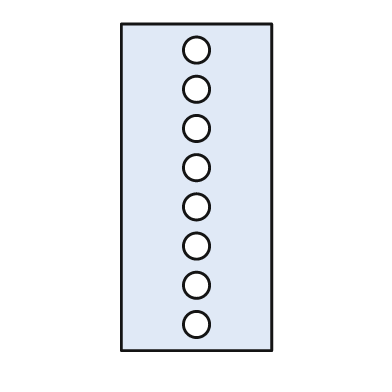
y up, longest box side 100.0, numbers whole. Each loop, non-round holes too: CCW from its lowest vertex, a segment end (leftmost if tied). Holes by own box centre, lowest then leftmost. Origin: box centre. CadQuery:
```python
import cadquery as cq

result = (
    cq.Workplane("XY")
    .moveTo(-23.0, -50.0)
    .lineTo(23.0, -50.0)
    .lineTo(23.0, 50.0)
    .lineTo(-23.0, 50.0)
    .close()
    .moveTo(0.0, -42.0)
    .circle(4.0)
    .moveTo(0.0, -30.0)
    .circle(4.0)
    .moveTo(0.0, -18.0)
    .circle(4.0)
    .moveTo(0.0, -6.0)
    .circle(4.0)
    .moveTo(0.0, 6.0)
    .circle(4.0)
    .moveTo(0.0, 18.0)
    .circle(4.0)
    .moveTo(0.0, 30.0)
    .circle(4.0)
    .moveTo(0.0, 42.0)
    .circle(4.0)
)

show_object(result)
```